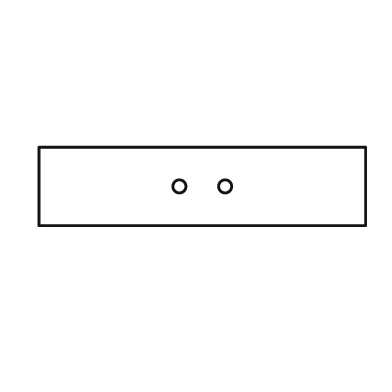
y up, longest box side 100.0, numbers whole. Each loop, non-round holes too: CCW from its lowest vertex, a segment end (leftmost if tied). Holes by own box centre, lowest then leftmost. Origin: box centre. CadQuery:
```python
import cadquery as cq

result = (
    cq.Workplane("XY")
    .moveTo(-50.0, -12.0)
    .lineTo(50.0, -12.0)
    .lineTo(50.0, 12.0)
    .lineTo(-50.0, 12.0)
    .close()
    .moveTo(-7.0, 0.0)
    .circle(2.0)
    .moveTo(7.0, 0.0)
    .circle(2.0)
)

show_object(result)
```